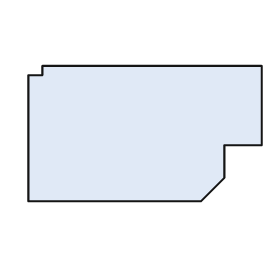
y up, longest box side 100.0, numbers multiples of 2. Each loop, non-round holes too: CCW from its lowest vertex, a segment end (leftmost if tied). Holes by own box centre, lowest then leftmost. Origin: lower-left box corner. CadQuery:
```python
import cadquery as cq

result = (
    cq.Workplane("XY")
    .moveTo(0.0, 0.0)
    .lineTo(74.0, 0.0)
    .lineTo(84.0, 10.0)
    .lineTo(84.0, 24.0)
    .lineTo(100.0, 24.0)
    .lineTo(100.0, 58.0)
    .lineTo(6.0, 58.0)
    .lineTo(6.0, 54.0)
    .lineTo(0.0, 54.0)
    .close()
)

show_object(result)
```